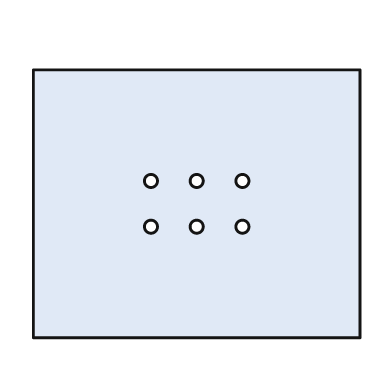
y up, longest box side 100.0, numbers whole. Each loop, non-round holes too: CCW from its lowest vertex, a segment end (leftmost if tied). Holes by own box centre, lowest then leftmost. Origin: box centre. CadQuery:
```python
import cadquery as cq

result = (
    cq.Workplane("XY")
    .moveTo(-50.0, -41.0)
    .lineTo(50.0, -41.0)
    .lineTo(50.0, 41.0)
    .lineTo(-50.0, 41.0)
    .close()
    .moveTo(-14.0, -7.0)
    .circle(2.0)
    .moveTo(0.0, -7.0)
    .circle(2.0)
    .moveTo(14.0, -7.0)
    .circle(2.0)
    .moveTo(-14.0, 7.0)
    .circle(2.0)
    .moveTo(0.0, 7.0)
    .circle(2.0)
    .moveTo(14.0, 7.0)
    .circle(2.0)
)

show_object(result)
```